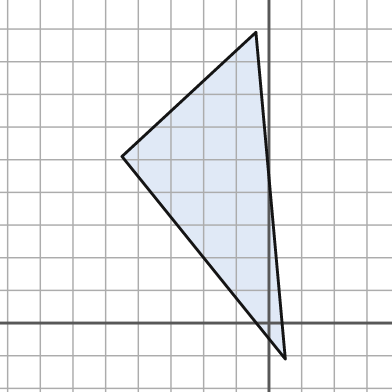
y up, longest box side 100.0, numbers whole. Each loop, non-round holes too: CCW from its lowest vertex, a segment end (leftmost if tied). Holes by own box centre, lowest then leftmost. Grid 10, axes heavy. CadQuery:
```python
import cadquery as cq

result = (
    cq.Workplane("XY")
    .moveTo(5.0, -11.0)
    .lineTo(-4.0, 89.0)
    .lineTo(-45.0, 51.0)
    .close()
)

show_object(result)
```